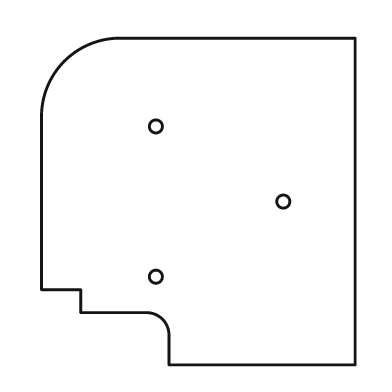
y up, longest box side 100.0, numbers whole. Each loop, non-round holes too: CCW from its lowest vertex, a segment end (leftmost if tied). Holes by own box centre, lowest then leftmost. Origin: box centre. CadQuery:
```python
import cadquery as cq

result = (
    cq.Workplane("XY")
    .moveTo(-9.0, -50.0)
    .lineTo(48.0, -50.0)
    .lineTo(48.0, 50.0)
    .lineTo(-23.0, 50.0)
    .threePointArc((-41.0, 43.0), (-48.0, 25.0))
    .lineTo(-48.0, -27.0)
    .lineTo(-36.0, -27.0)
    .lineTo(-36.0, -34.0)
    .lineTo(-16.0, -34.0)
    .threePointArc((-11.0, -36.0), (-9.0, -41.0))
    .close()
    .moveTo(-13.0, -23.0)
    .circle(2.0)
    .moveTo(26.0, 0.0)
    .circle(2.0)
    .moveTo(-13.0, 23.0)
    .circle(2.0)
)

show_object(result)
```